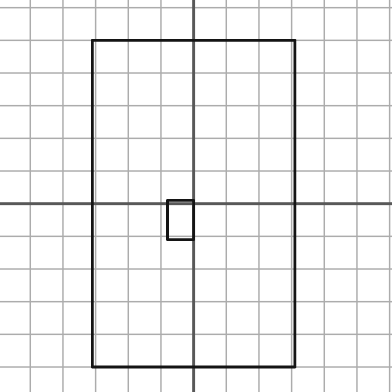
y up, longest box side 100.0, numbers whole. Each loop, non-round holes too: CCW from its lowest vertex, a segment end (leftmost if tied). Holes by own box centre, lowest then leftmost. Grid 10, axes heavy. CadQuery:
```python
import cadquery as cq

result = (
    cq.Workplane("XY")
    .moveTo(-31.0, -50.0)
    .lineTo(31.0, -50.0)
    .lineTo(31.0, 50.0)
    .lineTo(-31.0, 50.0)
    .close()
    .moveTo(-8.0, -11.0)
    .lineTo(0.0, -11.0)
    .lineTo(0.0, 1.0)
    .lineTo(-8.0, 1.0)
    .close()
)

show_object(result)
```